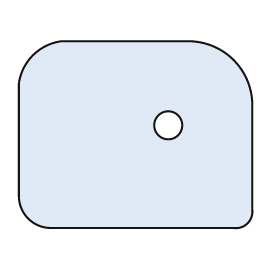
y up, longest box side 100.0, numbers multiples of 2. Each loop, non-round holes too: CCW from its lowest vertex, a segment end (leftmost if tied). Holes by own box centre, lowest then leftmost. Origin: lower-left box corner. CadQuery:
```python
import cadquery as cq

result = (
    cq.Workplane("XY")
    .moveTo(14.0, 0.0)
    .lineTo(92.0, 0.0)
    .threePointArc((98.0, 2.0), (100.0, 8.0))
    .lineTo(100.0, 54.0)
    .threePointArc((92.0, 72.0), (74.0, 80.0))
    .lineTo(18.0, 80.0)
    .threePointArc((6.0, 74.0), (0.0, 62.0))
    .lineTo(0.0, 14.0)
    .threePointArc((4.0, 4.0), (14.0, 0.0))
    .close()
    .moveTo(64.0, 44.0)
    .circle(6.0)
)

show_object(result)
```